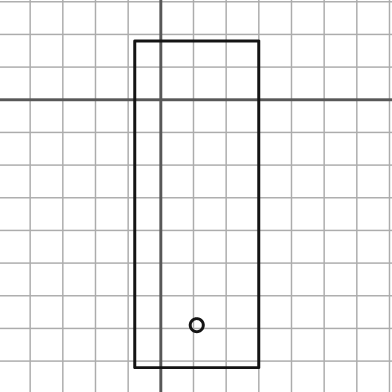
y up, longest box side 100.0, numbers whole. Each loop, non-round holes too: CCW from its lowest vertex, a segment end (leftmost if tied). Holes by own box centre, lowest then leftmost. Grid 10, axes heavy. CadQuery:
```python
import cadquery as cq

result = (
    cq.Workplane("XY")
    .moveTo(-8.0, -82.0)
    .lineTo(30.0, -82.0)
    .lineTo(30.0, 18.0)
    .lineTo(-8.0, 18.0)
    .close()
    .moveTo(11.0, -69.0)
    .circle(2.0)
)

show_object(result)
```